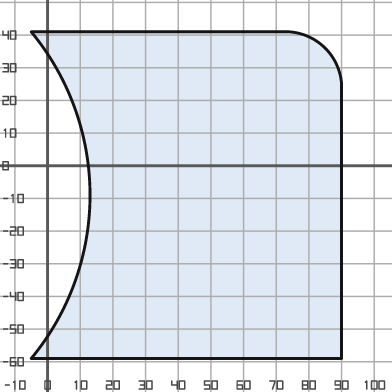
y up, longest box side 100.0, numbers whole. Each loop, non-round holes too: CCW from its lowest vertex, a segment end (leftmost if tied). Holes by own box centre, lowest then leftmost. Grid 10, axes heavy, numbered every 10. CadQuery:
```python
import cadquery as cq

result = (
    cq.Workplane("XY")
    .moveTo(-5.0, -59.0)
    .lineTo(90.0, -59.0)
    .lineTo(90.0, 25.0)
    .threePointArc((85.0, 36.0), (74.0, 41.0))
    .lineTo(-5.0, 41.0)
    .threePointArc((13.0, -9.0), (-5.0, -59.0))
    .close()
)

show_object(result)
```